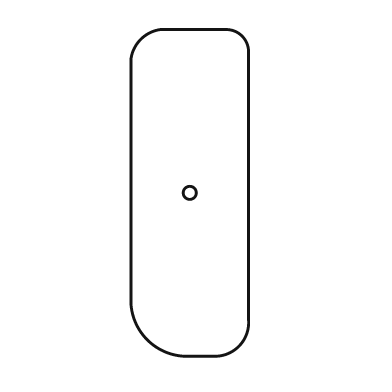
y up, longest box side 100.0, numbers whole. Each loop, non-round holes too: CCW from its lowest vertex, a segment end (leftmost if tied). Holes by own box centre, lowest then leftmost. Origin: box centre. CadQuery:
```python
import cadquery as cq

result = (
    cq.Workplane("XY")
    .moveTo(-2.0, -50.0)
    .lineTo(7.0, -50.0)
    .threePointArc((15.0, -47.0), (18.0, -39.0))
    .lineTo(18.0, 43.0)
    .threePointArc((16.0, 48.0), (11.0, 50.0))
    .lineTo(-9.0, 50.0)
    .threePointArc((-15.0, 47.0), (-18.0, 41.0))
    .lineTo(-18.0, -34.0)
    .threePointArc((-13.0, -45.0), (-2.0, -50.0))
    .close()
    .moveTo(0.0, 0.0)
    .circle(2.0)
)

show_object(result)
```